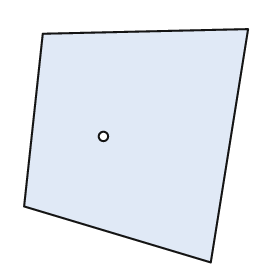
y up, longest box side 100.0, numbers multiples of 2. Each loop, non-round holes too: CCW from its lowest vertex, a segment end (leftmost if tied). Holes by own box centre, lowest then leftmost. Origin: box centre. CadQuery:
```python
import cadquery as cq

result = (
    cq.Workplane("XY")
    .moveTo(32.0, -50.0)
    .lineTo(48.0, 50.0)
    .lineTo(-40.0, 48.0)
    .lineTo(-48.0, -26.0)
    .close()
    .moveTo(-14.0, 4.0)
    .circle(2.0)
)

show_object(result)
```